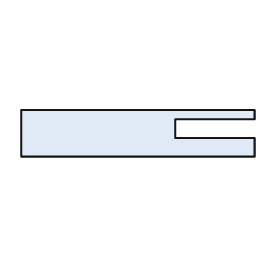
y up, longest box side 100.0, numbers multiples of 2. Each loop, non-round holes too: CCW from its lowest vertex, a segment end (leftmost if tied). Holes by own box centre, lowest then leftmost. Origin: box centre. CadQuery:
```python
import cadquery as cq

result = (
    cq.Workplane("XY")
    .moveTo(-50.0, -10.0)
    .lineTo(50.0, -10.0)
    .lineTo(50.0, -2.0)
    .lineTo(16.0, -2.0)
    .lineTo(16.0, 6.0)
    .lineTo(50.0, 6.0)
    .lineTo(50.0, 10.0)
    .lineTo(-50.0, 10.0)
    .close()
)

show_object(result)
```